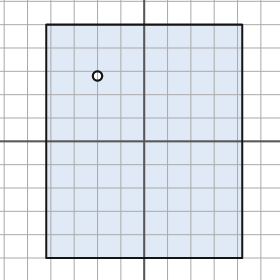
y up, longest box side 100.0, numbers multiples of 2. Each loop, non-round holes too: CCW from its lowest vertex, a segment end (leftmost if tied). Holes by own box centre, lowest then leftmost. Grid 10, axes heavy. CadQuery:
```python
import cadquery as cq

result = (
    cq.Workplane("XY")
    .moveTo(-42.0, -50.0)
    .lineTo(42.0, -50.0)
    .lineTo(42.0, 50.0)
    .lineTo(-42.0, 50.0)
    .close()
    .moveTo(-20.0, 28.0)
    .circle(2.0)
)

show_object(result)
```